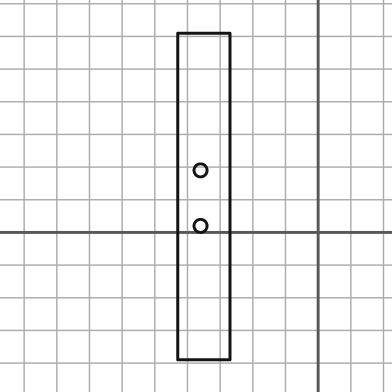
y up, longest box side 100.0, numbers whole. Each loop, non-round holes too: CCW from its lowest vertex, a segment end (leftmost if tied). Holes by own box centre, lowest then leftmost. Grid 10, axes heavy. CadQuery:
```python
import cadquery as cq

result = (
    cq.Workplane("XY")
    .moveTo(-43.0, -39.0)
    .lineTo(-27.0, -39.0)
    .lineTo(-27.0, 61.0)
    .lineTo(-43.0, 61.0)
    .close()
    .moveTo(-36.0, 2.0)
    .circle(2.0)
    .moveTo(-36.0, 19.0)
    .circle(2.0)
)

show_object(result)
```